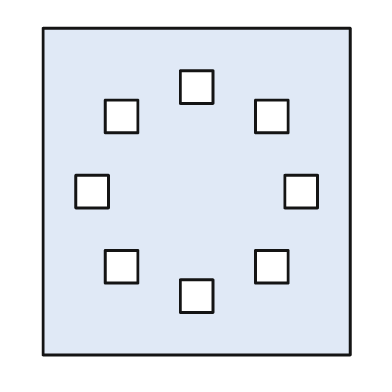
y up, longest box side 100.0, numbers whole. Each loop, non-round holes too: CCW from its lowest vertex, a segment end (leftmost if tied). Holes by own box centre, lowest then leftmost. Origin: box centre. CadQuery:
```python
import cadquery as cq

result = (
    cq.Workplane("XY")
    .moveTo(-47.0, -50.0)
    .lineTo(47.0, -50.0)
    .lineTo(47.0, 50.0)
    .lineTo(-47.0, 50.0)
    .close()
    .moveTo(-5.0, -37.0)
    .lineTo(5.0, -37.0)
    .lineTo(5.0, -27.0)
    .lineTo(-5.0, -27.0)
    .close()
    .moveTo(-28.0, -28.0)
    .lineTo(-18.0, -28.0)
    .lineTo(-18.0, -18.0)
    .lineTo(-28.0, -18.0)
    .close()
    .moveTo(18.0, -28.0)
    .lineTo(28.0, -28.0)
    .lineTo(28.0, -18.0)
    .lineTo(18.0, -18.0)
    .close()
    .moveTo(-37.0, -5.0)
    .lineTo(-27.0, -5.0)
    .lineTo(-27.0, 5.0)
    .lineTo(-37.0, 5.0)
    .close()
    .moveTo(27.0, -5.0)
    .lineTo(37.0, -5.0)
    .lineTo(37.0, 5.0)
    .lineTo(27.0, 5.0)
    .close()
    .moveTo(-28.0, 18.0)
    .lineTo(-18.0, 18.0)
    .lineTo(-18.0, 28.0)
    .lineTo(-28.0, 28.0)
    .close()
    .moveTo(18.0, 18.0)
    .lineTo(28.0, 18.0)
    .lineTo(28.0, 28.0)
    .lineTo(18.0, 28.0)
    .close()
    .moveTo(-5.0, 27.0)
    .lineTo(5.0, 27.0)
    .lineTo(5.0, 37.0)
    .lineTo(-5.0, 37.0)
    .close()
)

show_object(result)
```